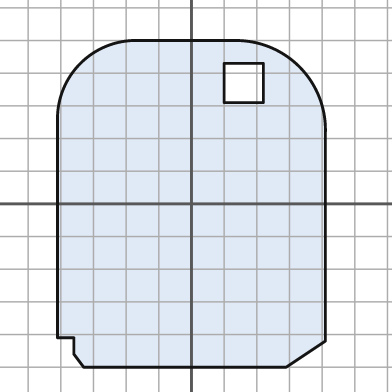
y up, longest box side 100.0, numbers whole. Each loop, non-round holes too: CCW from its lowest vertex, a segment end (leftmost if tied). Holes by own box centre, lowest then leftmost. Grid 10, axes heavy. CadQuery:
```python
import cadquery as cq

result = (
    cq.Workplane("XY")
    .moveTo(-33.0, -50.0)
    .lineTo(29.0, -50.0)
    .lineTo(41.0, -42.0)
    .lineTo(41.0, 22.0)
    .threePointArc((33.0, 42.0), (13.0, 50.0))
    .lineTo(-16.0, 50.0)
    .threePointArc((-34.0, 43.0), (-41.0, 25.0))
    .lineTo(-41.0, -41.0)
    .lineTo(-36.0, -41.0)
    .lineTo(-36.0, -46.0)
    .close()
    .moveTo(10.0, 31.0)
    .lineTo(22.0, 31.0)
    .lineTo(22.0, 43.0)
    .lineTo(10.0, 43.0)
    .close()
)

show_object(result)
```